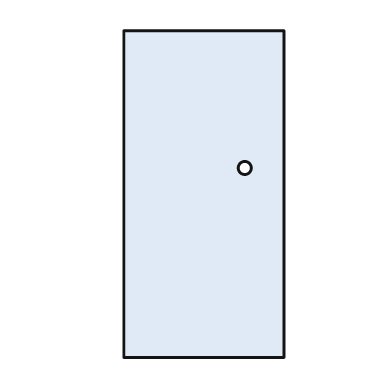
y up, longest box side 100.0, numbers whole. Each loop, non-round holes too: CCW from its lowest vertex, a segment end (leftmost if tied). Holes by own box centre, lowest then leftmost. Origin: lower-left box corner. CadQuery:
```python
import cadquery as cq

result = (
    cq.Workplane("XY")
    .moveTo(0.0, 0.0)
    .lineTo(49.0, 0.0)
    .lineTo(49.0, 100.0)
    .lineTo(0.0, 100.0)
    .close()
    .moveTo(37.0, 58.0)
    .circle(2.0)
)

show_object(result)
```